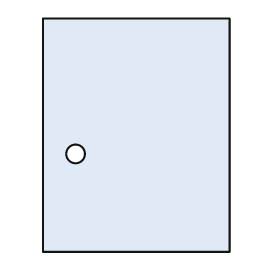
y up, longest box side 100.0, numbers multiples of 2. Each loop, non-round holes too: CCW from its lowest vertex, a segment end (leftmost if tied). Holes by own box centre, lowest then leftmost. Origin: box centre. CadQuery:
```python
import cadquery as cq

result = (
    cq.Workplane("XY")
    .moveTo(-40.0, -50.0)
    .lineTo(40.0, -50.0)
    .lineTo(40.0, 50.0)
    .lineTo(-40.0, 50.0)
    .close()
    .moveTo(-26.0, -8.0)
    .circle(4.0)
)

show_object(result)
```